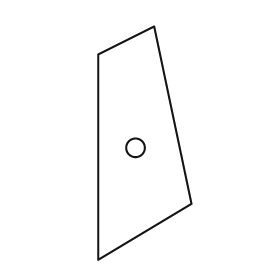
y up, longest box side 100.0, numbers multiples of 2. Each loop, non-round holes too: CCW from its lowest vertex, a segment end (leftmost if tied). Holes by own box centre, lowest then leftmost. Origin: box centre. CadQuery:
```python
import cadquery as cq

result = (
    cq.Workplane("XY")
    .moveTo(-20.0, -50.0)
    .lineTo(20.0, -26.0)
    .lineTo(4.0, 50.0)
    .lineTo(-20.0, 38.0)
    .close()
    .moveTo(-4.0, -2.0)
    .circle(4.0)
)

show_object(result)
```